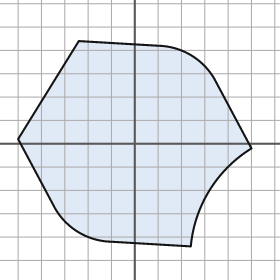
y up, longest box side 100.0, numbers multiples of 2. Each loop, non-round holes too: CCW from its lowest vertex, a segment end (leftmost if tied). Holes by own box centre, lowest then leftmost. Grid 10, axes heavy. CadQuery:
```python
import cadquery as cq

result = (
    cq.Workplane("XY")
    .moveTo(24.0, -44.0)
    .threePointArc((32.0, -20.0), (50.0, -2.0))
    .lineTo(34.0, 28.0)
    .threePointArc((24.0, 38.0), (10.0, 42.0))
    .lineTo(-24.0, 44.0)
    .lineTo(-50.0, 2.0)
    .lineTo(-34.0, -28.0)
    .threePointArc((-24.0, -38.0), (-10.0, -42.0))
    .close()
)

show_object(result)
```